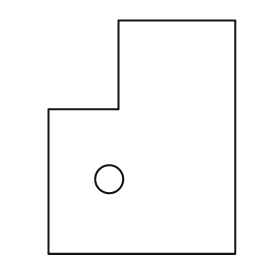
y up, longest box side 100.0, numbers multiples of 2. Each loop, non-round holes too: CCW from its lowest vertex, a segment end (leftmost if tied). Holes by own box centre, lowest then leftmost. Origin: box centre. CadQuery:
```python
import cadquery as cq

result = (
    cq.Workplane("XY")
    .moveTo(-40.0, -50.0)
    .lineTo(40.0, -50.0)
    .lineTo(40.0, 50.0)
    .lineTo(-10.0, 50.0)
    .lineTo(-10.0, 12.0)
    .lineTo(-40.0, 12.0)
    .close()
    .moveTo(-14.0, -18.0)
    .circle(6.0)
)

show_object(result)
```